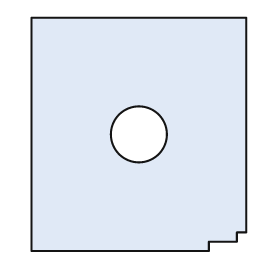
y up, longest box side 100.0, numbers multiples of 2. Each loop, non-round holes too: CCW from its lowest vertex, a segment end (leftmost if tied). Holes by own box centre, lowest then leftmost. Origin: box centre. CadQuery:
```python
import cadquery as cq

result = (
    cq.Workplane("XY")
    .moveTo(-46.0, -50.0)
    .lineTo(30.0, -50.0)
    .lineTo(30.0, -46.0)
    .lineTo(42.0, -46.0)
    .lineTo(42.0, -42.0)
    .lineTo(46.0, -42.0)
    .lineTo(46.0, 50.0)
    .lineTo(-46.0, 50.0)
    .close()
    .moveTo(0.0, 0.0)
    .circle(12.0)
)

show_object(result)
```